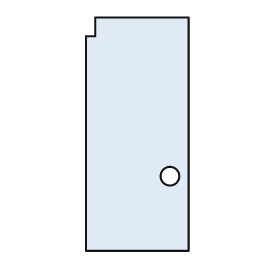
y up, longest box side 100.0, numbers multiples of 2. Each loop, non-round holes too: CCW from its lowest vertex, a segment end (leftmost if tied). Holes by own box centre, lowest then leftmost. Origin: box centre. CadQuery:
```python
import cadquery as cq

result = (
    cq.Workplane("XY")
    .moveTo(-22.0, -50.0)
    .lineTo(22.0, -50.0)
    .lineTo(22.0, 50.0)
    .lineTo(-18.0, 50.0)
    .lineTo(-18.0, 42.0)
    .lineTo(-22.0, 42.0)
    .close()
    .moveTo(14.0, -18.0)
    .circle(4.0)
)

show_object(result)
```